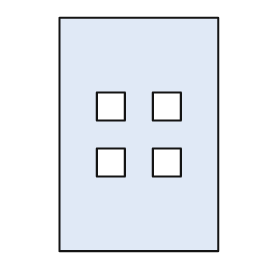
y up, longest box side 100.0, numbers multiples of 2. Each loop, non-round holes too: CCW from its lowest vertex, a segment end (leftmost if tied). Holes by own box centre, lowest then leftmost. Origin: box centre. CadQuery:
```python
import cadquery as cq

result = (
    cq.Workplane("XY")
    .moveTo(-34.0, -50.0)
    .lineTo(34.0, -50.0)
    .lineTo(34.0, 50.0)
    .lineTo(-34.0, 50.0)
    .close()
    .moveTo(-18.0, -18.0)
    .lineTo(-6.0, -18.0)
    .lineTo(-6.0, -6.0)
    .lineTo(-18.0, -6.0)
    .close()
    .moveTo(6.0, -18.0)
    .lineTo(18.0, -18.0)
    .lineTo(18.0, -6.0)
    .lineTo(6.0, -6.0)
    .close()
    .moveTo(-18.0, 6.0)
    .lineTo(-6.0, 6.0)
    .lineTo(-6.0, 18.0)
    .lineTo(-18.0, 18.0)
    .close()
    .moveTo(6.0, 6.0)
    .lineTo(18.0, 6.0)
    .lineTo(18.0, 18.0)
    .lineTo(6.0, 18.0)
    .close()
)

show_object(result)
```